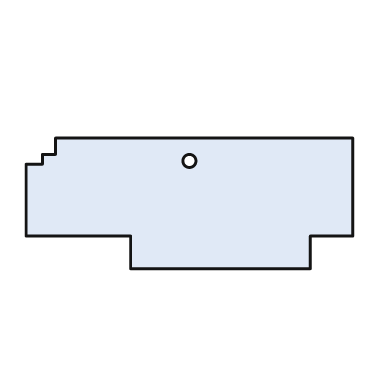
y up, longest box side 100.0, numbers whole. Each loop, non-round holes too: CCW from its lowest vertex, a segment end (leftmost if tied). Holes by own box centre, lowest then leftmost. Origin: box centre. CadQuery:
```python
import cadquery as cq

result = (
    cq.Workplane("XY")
    .moveTo(-18.0, -20.0)
    .lineTo(37.0, -20.0)
    .lineTo(37.0, -10.0)
    .lineTo(50.0, -10.0)
    .lineTo(50.0, 20.0)
    .lineTo(-41.0, 20.0)
    .lineTo(-41.0, 15.0)
    .lineTo(-45.0, 15.0)
    .lineTo(-45.0, 12.0)
    .lineTo(-50.0, 12.0)
    .lineTo(-50.0, -10.0)
    .lineTo(-18.0, -10.0)
    .close()
    .moveTo(0.0, 13.0)
    .circle(2.0)
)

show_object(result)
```